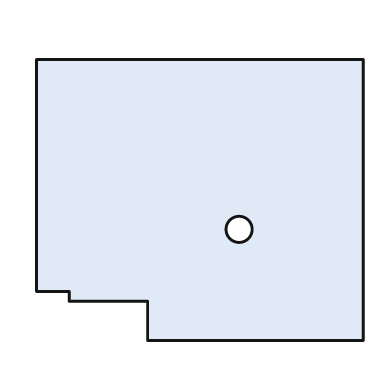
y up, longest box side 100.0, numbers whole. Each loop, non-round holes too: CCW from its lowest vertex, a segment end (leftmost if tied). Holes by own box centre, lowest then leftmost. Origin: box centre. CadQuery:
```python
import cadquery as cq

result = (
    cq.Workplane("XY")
    .moveTo(-16.0, -43.0)
    .lineTo(50.0, -43.0)
    .lineTo(50.0, 43.0)
    .lineTo(-50.0, 43.0)
    .lineTo(-50.0, -28.0)
    .lineTo(-40.0, -28.0)
    .lineTo(-40.0, -31.0)
    .lineTo(-16.0, -31.0)
    .close()
    .moveTo(12.0, -9.0)
    .circle(4.0)
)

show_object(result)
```